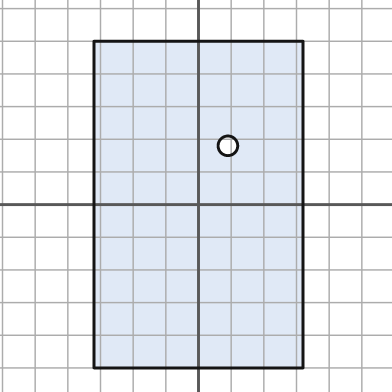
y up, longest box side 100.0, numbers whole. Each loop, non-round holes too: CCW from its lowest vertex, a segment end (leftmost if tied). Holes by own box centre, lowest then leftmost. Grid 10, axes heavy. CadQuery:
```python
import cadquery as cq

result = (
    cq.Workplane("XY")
    .moveTo(-32.0, -50.0)
    .lineTo(32.0, -50.0)
    .lineTo(32.0, 50.0)
    .lineTo(-32.0, 50.0)
    .close()
    .moveTo(9.0, 18.0)
    .circle(3.0)
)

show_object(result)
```